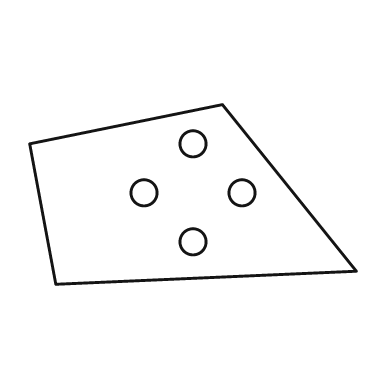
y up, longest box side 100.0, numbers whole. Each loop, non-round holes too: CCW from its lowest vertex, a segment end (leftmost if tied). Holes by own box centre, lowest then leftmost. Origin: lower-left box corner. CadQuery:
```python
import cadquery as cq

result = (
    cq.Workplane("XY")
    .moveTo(8.0, 0.0)
    .lineTo(100.0, 4.0)
    .lineTo(59.0, 55.0)
    .lineTo(0.0, 43.0)
    .close()
    .moveTo(50.0, 13.0)
    .circle(4.0)
    .moveTo(35.0, 28.0)
    .circle(4.0)
    .moveTo(65.0, 28.0)
    .circle(4.0)
    .moveTo(50.0, 43.0)
    .circle(4.0)
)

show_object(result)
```